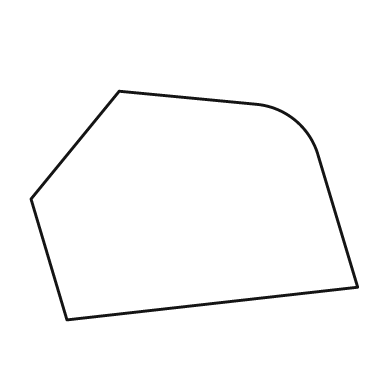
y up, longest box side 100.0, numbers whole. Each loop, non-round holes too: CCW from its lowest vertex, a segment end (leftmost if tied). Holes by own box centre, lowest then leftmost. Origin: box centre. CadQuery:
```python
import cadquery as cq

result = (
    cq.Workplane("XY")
    .moveTo(-39.0, -35.0)
    .lineTo(50.0, -25.0)
    .lineTo(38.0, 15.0)
    .threePointArc((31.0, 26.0), (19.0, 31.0))
    .lineTo(-23.0, 35.0)
    .lineTo(-50.0, 2.0)
    .close()
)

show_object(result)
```